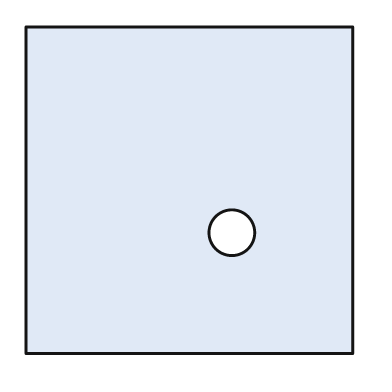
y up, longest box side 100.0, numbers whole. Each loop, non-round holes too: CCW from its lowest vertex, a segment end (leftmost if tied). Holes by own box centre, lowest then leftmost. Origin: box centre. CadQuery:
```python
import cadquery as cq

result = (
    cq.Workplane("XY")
    .moveTo(-50.0, -50.0)
    .lineTo(50.0, -50.0)
    .lineTo(50.0, 50.0)
    .lineTo(-50.0, 50.0)
    .close()
    .moveTo(13.0, -13.0)
    .circle(7.0)
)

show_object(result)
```